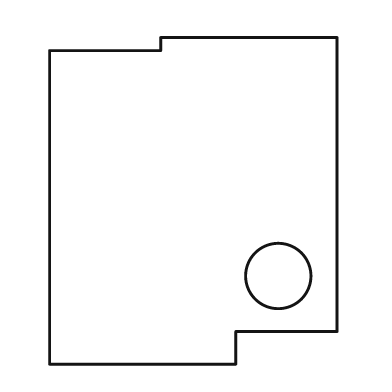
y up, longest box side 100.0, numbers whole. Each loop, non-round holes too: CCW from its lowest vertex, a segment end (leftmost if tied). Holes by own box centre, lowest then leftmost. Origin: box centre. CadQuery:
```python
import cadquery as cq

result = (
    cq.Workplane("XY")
    .moveTo(-44.0, -50.0)
    .lineTo(13.0, -50.0)
    .lineTo(13.0, -40.0)
    .lineTo(44.0, -40.0)
    .lineTo(44.0, 50.0)
    .lineTo(-10.0, 50.0)
    .lineTo(-10.0, 46.0)
    .lineTo(-44.0, 46.0)
    .close()
    .moveTo(26.0, -23.0)
    .circle(10.0)
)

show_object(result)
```